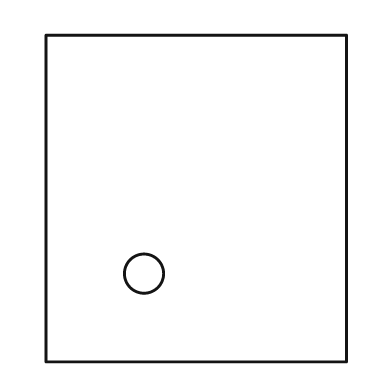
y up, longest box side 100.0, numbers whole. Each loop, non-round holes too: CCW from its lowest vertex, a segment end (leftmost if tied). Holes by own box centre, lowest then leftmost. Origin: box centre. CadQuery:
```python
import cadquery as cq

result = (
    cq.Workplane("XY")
    .moveTo(-46.0, -50.0)
    .lineTo(46.0, -50.0)
    .lineTo(46.0, 50.0)
    .lineTo(-46.0, 50.0)
    .close()
    .moveTo(-16.0, -23.0)
    .circle(6.0)
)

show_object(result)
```